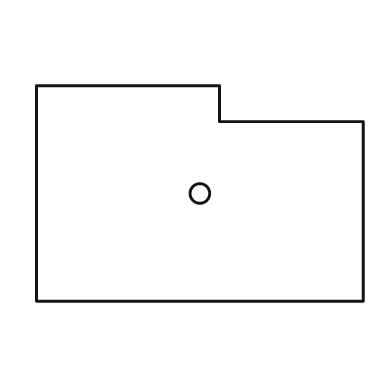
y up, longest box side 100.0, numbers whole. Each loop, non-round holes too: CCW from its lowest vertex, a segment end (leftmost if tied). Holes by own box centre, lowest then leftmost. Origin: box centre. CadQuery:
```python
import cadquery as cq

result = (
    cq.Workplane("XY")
    .moveTo(-50.0, -33.0)
    .lineTo(50.0, -33.0)
    .lineTo(50.0, 22.0)
    .lineTo(6.0, 22.0)
    .lineTo(6.0, 33.0)
    .lineTo(-50.0, 33.0)
    .close()
    .moveTo(0.0, 0.0)
    .circle(3.0)
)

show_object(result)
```